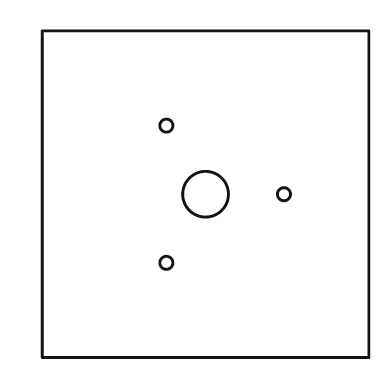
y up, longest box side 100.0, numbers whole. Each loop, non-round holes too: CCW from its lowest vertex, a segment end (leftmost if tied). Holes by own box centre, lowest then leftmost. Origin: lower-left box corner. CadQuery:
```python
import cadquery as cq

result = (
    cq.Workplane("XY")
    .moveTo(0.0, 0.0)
    .lineTo(100.0, 0.0)
    .lineTo(100.0, 100.0)
    .lineTo(0.0, 100.0)
    .close()
    .moveTo(38.0, 29.0)
    .circle(2.0)
    .moveTo(50.0, 50.0)
    .circle(7.0)
    .moveTo(74.0, 50.0)
    .circle(2.0)
    .moveTo(38.0, 71.0)
    .circle(2.0)
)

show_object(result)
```